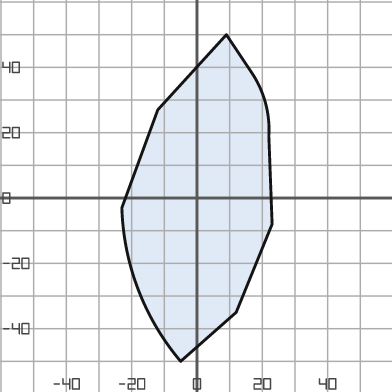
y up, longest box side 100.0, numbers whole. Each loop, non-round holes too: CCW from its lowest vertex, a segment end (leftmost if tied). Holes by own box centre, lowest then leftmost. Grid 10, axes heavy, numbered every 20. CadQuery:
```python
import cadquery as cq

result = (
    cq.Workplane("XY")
    .moveTo(-5.0, -50.0)
    .lineTo(12.0, -35.0)
    .lineTo(23.0, -8.0)
    .lineTo(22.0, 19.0)
    .threePointArc((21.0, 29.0), (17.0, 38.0))
    .lineTo(9.0, 50.0)
    .lineTo(-12.0, 27.0)
    .lineTo(-23.0, -3.0)
    .threePointArc((-18.0, -28.0), (-5.0, -50.0))
    .close()
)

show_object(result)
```